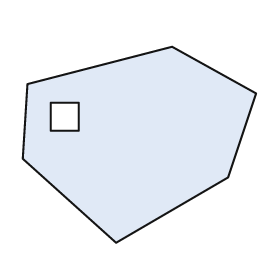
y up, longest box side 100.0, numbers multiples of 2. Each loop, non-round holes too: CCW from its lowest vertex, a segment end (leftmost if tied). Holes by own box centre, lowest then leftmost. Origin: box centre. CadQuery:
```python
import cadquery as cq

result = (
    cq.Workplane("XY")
    .moveTo(-10.0, -42.0)
    .lineTo(38.0, -14.0)
    .lineTo(50.0, 22.0)
    .lineTo(14.0, 42.0)
    .lineTo(-48.0, 26.0)
    .lineTo(-50.0, -6.0)
    .close()
    .moveTo(-38.0, 6.0)
    .lineTo(-26.0, 6.0)
    .lineTo(-26.0, 18.0)
    .lineTo(-38.0, 18.0)
    .close()
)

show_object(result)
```